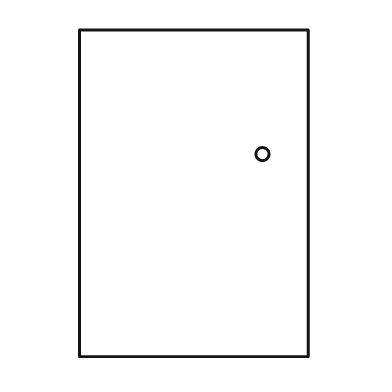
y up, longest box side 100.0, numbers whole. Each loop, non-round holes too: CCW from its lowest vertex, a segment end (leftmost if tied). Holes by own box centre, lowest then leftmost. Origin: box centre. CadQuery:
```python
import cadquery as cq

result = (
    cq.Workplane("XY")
    .moveTo(-35.0, -50.0)
    .lineTo(35.0, -50.0)
    .lineTo(35.0, 50.0)
    .lineTo(-35.0, 50.0)
    .close()
    .moveTo(21.0, 12.0)
    .circle(2.0)
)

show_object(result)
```